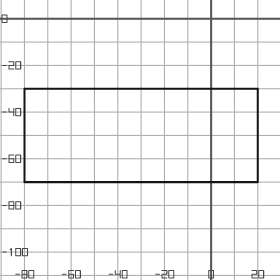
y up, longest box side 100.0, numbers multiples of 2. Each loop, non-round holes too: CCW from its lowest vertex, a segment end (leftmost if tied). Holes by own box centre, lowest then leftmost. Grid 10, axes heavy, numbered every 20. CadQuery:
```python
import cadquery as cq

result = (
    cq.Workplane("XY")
    .moveTo(-80.0, -70.0)
    .lineTo(20.0, -70.0)
    .lineTo(20.0, -30.0)
    .lineTo(-80.0, -30.0)
    .close()
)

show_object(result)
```